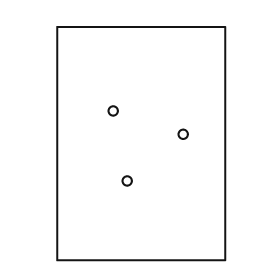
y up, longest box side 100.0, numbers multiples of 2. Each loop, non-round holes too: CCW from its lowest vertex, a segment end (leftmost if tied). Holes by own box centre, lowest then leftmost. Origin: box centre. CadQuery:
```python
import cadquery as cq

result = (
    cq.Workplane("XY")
    .moveTo(-36.0, -50.0)
    .lineTo(36.0, -50.0)
    .lineTo(36.0, 50.0)
    .lineTo(-36.0, 50.0)
    .close()
    .moveTo(-6.0, -16.0)
    .circle(2.0)
    .moveTo(18.0, 4.0)
    .circle(2.0)
    .moveTo(-12.0, 14.0)
    .circle(2.0)
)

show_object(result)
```